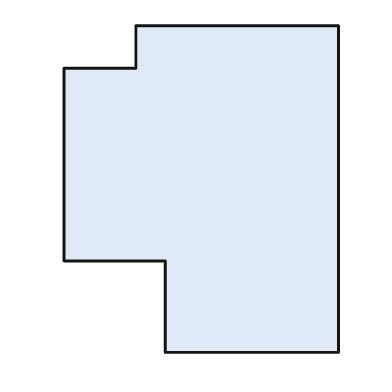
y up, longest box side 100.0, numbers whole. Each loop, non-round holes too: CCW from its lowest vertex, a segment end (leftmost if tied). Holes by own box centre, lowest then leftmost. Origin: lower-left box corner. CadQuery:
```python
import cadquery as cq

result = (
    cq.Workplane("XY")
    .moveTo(31.0, 0.0)
    .lineTo(84.0, 0.0)
    .lineTo(84.0, 100.0)
    .lineTo(22.0, 100.0)
    .lineTo(22.0, 87.0)
    .lineTo(0.0, 87.0)
    .lineTo(0.0, 28.0)
    .lineTo(31.0, 28.0)
    .close()
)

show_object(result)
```